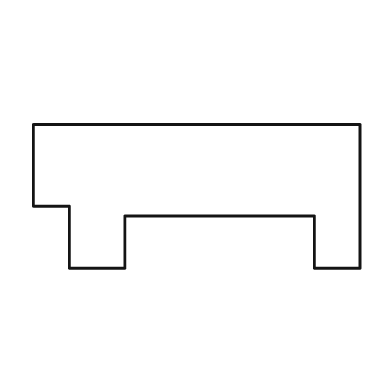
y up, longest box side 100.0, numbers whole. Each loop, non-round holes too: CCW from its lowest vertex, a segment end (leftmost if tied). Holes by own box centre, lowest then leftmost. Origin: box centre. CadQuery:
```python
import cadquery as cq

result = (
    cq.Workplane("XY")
    .moveTo(-39.0, -22.0)
    .lineTo(-22.0, -22.0)
    .lineTo(-22.0, -6.0)
    .lineTo(36.0, -6.0)
    .lineTo(36.0, -22.0)
    .lineTo(50.0, -22.0)
    .lineTo(50.0, 22.0)
    .lineTo(-50.0, 22.0)
    .lineTo(-50.0, -3.0)
    .lineTo(-39.0, -3.0)
    .close()
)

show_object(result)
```